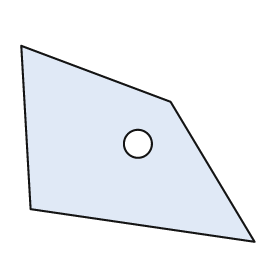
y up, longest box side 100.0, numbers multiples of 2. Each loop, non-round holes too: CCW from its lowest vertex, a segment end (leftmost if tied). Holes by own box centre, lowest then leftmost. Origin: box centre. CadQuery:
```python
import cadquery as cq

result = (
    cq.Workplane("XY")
    .moveTo(50.0, -42.0)
    .lineTo(14.0, 18.0)
    .lineTo(-50.0, 42.0)
    .lineTo(-46.0, -28.0)
    .close()
    .moveTo(0.0, 0.0)
    .circle(6.0)
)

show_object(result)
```